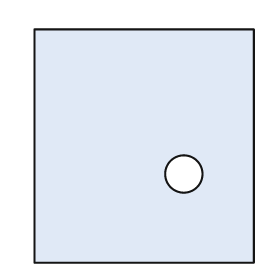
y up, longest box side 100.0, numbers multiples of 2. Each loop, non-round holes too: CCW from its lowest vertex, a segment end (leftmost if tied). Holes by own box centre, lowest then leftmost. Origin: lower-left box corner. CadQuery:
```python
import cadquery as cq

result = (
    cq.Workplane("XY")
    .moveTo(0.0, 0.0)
    .lineTo(94.0, 0.0)
    .lineTo(94.0, 100.0)
    .lineTo(0.0, 100.0)
    .close()
    .moveTo(64.0, 38.0)
    .circle(8.0)
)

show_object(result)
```